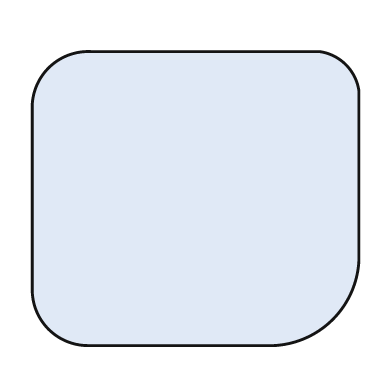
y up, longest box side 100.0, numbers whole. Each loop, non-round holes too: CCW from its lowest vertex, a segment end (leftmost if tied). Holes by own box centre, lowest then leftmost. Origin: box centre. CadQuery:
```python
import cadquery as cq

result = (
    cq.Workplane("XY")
    .moveTo(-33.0, -45.0)
    .lineTo(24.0, -45.0)
    .threePointArc((42.0, -37.0), (50.0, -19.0))
    .lineTo(50.0, 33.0)
    .threePointArc((46.0, 41.0), (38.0, 45.0))
    .lineTo(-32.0, 45.0)
    .threePointArc((-45.0, 40.0), (-50.0, 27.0))
    .lineTo(-50.0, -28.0)
    .threePointArc((-45.0, -40.0), (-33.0, -45.0))
    .close()
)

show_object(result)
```